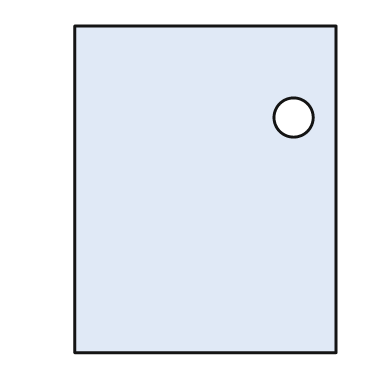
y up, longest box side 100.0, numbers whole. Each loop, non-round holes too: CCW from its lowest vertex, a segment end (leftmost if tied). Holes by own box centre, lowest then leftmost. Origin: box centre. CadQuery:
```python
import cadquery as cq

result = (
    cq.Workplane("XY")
    .moveTo(-40.0, -50.0)
    .lineTo(40.0, -50.0)
    .lineTo(40.0, 50.0)
    .lineTo(-40.0, 50.0)
    .close()
    .moveTo(27.0, 22.0)
    .circle(6.0)
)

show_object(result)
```